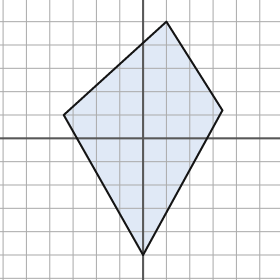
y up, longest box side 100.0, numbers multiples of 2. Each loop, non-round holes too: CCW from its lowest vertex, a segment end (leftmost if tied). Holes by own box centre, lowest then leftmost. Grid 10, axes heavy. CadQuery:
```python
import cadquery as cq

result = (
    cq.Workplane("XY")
    .moveTo(0.0, -50.0)
    .lineTo(34.0, 12.0)
    .lineTo(10.0, 50.0)
    .lineTo(-34.0, 10.0)
    .close()
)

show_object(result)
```